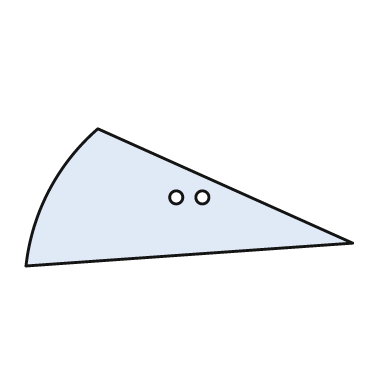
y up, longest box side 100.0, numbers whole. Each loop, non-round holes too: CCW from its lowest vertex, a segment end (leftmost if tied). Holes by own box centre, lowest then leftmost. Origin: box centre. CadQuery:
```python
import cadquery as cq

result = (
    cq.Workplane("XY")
    .moveTo(-50.0, -21.0)
    .lineTo(50.0, -14.0)
    .lineTo(-28.0, 21.0)
    .threePointArc((-43.0, 2.0), (-50.0, -21.0))
    .close()
    .moveTo(-4.0, 0.0)
    .circle(2.0)
    .moveTo(4.0, 0.0)
    .circle(2.0)
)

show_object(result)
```